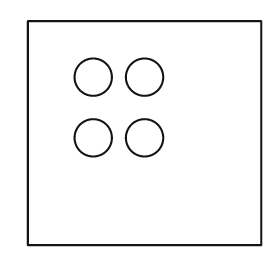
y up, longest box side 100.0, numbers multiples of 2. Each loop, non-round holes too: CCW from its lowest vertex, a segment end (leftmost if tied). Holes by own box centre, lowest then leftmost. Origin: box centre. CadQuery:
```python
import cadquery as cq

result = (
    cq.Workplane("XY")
    .moveTo(-50.0, -48.0)
    .lineTo(50.0, -48.0)
    .lineTo(50.0, 48.0)
    .lineTo(-50.0, 48.0)
    .close()
    .moveTo(-22.0, -2.0)
    .circle(8.0)
    .moveTo(0.0, -2.0)
    .circle(8.0)
    .moveTo(-22.0, 24.0)
    .circle(8.0)
    .moveTo(0.0, 24.0)
    .circle(8.0)
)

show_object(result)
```